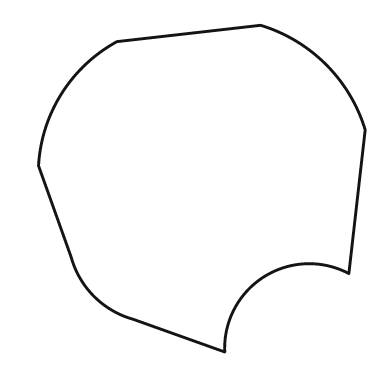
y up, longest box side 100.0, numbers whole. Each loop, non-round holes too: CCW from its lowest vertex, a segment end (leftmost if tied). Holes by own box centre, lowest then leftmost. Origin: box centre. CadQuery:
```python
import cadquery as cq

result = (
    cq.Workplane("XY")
    .moveTo(7.0, -50.0)
    .threePointArc((19.0, -27.0), (45.0, -26.0))
    .lineTo(50.0, 18.0)
    .threePointArc((38.0, 38.0), (18.0, 50.0))
    .lineTo(-26.0, 45.0)
    .threePointArc((-43.0, 29.0), (-50.0, 7.0))
    .lineTo(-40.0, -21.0)
    .threePointArc((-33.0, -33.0), (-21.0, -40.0))
    .close()
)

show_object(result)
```